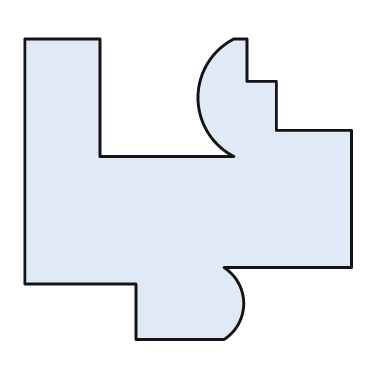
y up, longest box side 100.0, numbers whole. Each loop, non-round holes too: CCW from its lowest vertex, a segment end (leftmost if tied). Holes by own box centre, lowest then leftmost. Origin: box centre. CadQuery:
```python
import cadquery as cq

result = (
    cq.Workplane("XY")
    .moveTo(-16.0, -46.0)
    .lineTo(11.0, -46.0)
    .threePointArc((17.0, -35.0), (11.0, -24.0))
    .lineTo(50.0, -24.0)
    .lineTo(50.0, 18.0)
    .lineTo(27.0, 18.0)
    .lineTo(27.0, 33.0)
    .lineTo(18.0, 33.0)
    .lineTo(18.0, 46.0)
    .lineTo(14.0, 46.0)
    .threePointArc((3.0, 28.0), (14.0, 10.0))
    .lineTo(-27.0, 10.0)
    .lineTo(-27.0, 46.0)
    .lineTo(-50.0, 46.0)
    .lineTo(-50.0, -29.0)
    .lineTo(-16.0, -29.0)
    .close()
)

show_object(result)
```